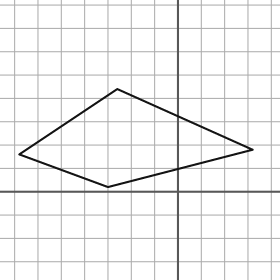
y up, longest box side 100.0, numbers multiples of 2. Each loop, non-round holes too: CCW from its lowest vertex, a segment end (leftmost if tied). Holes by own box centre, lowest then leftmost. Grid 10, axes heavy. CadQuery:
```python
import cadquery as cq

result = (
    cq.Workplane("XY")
    .moveTo(-30.0, 2.0)
    .lineTo(32.0, 18.0)
    .lineTo(-26.0, 44.0)
    .lineTo(-68.0, 16.0)
    .close()
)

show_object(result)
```